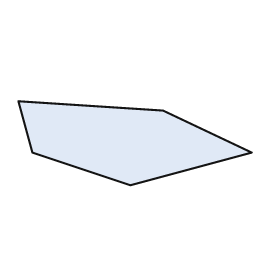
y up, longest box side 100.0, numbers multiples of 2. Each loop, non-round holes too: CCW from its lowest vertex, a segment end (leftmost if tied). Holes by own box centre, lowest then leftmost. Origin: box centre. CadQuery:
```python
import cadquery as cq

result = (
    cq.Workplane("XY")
    .moveTo(-2.0, -18.0)
    .lineTo(50.0, -4.0)
    .lineTo(12.0, 14.0)
    .lineTo(-50.0, 18.0)
    .lineTo(-44.0, -4.0)
    .close()
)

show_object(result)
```